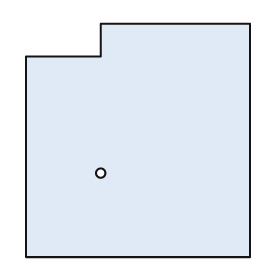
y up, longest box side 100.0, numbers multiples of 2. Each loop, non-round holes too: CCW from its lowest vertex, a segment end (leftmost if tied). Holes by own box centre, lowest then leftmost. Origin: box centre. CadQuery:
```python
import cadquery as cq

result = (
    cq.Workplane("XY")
    .moveTo(-48.0, -50.0)
    .lineTo(48.0, -50.0)
    .lineTo(48.0, 50.0)
    .lineTo(-16.0, 50.0)
    .lineTo(-16.0, 36.0)
    .lineTo(-48.0, 36.0)
    .close()
    .moveTo(-16.0, -14.0)
    .circle(2.0)
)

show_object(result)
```